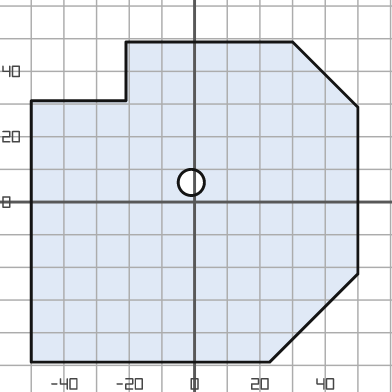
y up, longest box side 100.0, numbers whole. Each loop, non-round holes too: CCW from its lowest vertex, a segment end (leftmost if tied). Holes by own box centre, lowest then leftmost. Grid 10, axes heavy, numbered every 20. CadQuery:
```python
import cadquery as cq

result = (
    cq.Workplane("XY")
    .moveTo(-50.0, -49.0)
    .lineTo(23.0, -49.0)
    .lineTo(50.0, -22.0)
    .lineTo(50.0, 29.0)
    .lineTo(30.0, 49.0)
    .lineTo(-21.0, 49.0)
    .lineTo(-21.0, 31.0)
    .lineTo(-50.0, 31.0)
    .close()
    .moveTo(-1.0, 6.0)
    .circle(4.0)
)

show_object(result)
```